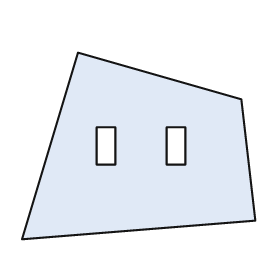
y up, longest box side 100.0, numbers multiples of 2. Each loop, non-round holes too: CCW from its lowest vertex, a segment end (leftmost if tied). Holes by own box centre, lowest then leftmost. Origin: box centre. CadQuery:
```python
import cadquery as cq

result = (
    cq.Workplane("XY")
    .moveTo(-50.0, -40.0)
    .lineTo(50.0, -32.0)
    .lineTo(44.0, 20.0)
    .lineTo(-26.0, 40.0)
    .close()
    .moveTo(-18.0, -8.0)
    .lineTo(-10.0, -8.0)
    .lineTo(-10.0, 8.0)
    .lineTo(-18.0, 8.0)
    .close()
    .moveTo(12.0, -8.0)
    .lineTo(20.0, -8.0)
    .lineTo(20.0, 8.0)
    .lineTo(12.0, 8.0)
    .close()
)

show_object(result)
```